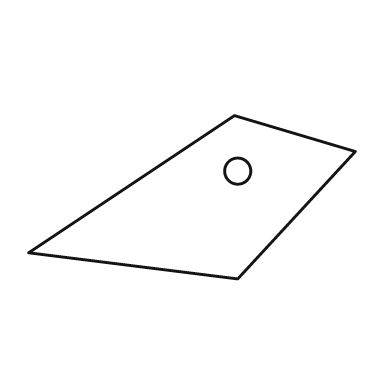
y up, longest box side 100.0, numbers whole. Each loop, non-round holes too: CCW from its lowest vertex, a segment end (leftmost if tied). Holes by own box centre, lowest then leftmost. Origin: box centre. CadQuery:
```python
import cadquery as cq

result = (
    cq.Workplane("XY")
    .moveTo(14.0, -25.0)
    .lineTo(50.0, 14.0)
    .lineTo(13.0, 25.0)
    .lineTo(-50.0, -17.0)
    .close()
    .moveTo(14.0, 8.0)
    .circle(4.0)
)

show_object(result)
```